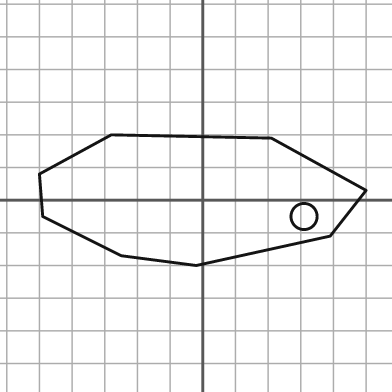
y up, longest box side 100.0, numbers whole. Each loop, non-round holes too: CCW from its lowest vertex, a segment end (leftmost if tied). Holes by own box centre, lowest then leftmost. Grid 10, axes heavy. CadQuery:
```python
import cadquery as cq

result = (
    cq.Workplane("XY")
    .moveTo(-2.0, -20.0)
    .lineTo(39.0, -11.0)
    .lineTo(50.0, 3.0)
    .lineTo(21.0, 19.0)
    .lineTo(-28.0, 20.0)
    .lineTo(-50.0, 8.0)
    .lineTo(-49.0, -5.0)
    .lineTo(-25.0, -17.0)
    .close()
    .moveTo(31.0, -5.0)
    .circle(4.0)
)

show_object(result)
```